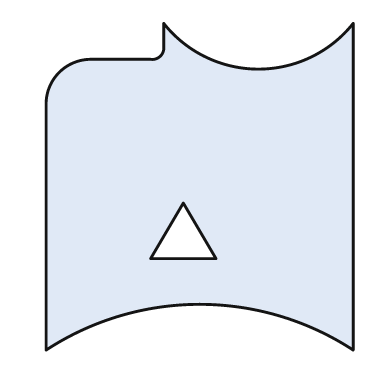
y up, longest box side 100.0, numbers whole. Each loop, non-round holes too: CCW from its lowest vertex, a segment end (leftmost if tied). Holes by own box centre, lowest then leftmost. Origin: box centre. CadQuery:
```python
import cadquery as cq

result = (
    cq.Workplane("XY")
    .moveTo(-47.0, -50.0)
    .threePointArc((0.0, -36.0), (47.0, -50.0))
    .lineTo(47.0, 50.0)
    .threePointArc((18.0, 36.0), (-11.0, 50.0))
    .lineTo(-11.0, 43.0)
    .threePointArc((-12.0, 40.0), (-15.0, 39.0))
    .lineTo(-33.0, 39.0)
    .threePointArc((-43.0, 35.0), (-47.0, 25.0))
    .close()
    .moveTo(-15.0, -22.0)
    .lineTo(5.0, -22.0)
    .lineTo(-5.0, -5.0)
    .close()
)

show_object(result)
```